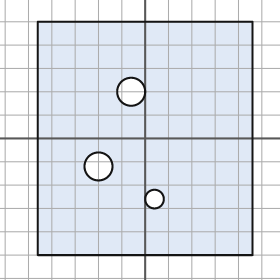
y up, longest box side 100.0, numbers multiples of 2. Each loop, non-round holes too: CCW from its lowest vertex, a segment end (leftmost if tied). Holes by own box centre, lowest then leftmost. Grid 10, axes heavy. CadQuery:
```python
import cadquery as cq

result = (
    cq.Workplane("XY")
    .moveTo(-46.0, -50.0)
    .lineTo(46.0, -50.0)
    .lineTo(46.0, 50.0)
    .lineTo(-46.0, 50.0)
    .close()
    .moveTo(4.0, -26.0)
    .circle(4.0)
    .moveTo(-20.0, -12.0)
    .circle(6.0)
    .moveTo(-6.0, 20.0)
    .circle(6.0)
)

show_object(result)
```